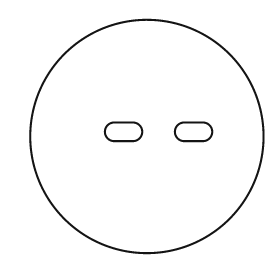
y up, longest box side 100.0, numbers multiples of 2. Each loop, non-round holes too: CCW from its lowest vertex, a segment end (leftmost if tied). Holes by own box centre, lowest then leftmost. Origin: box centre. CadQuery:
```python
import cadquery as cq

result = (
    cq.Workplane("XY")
    .moveTo(0.0, 0.0)
    .circle(50.0)
    .moveTo(-14.0, -2.0)
    .lineTo(-6.0, -2.0)
    .threePointArc((-2.0, 2.0), (-6.0, 6.0))
    .lineTo(-14.0, 6.0)
    .threePointArc((-18.0, 2.0), (-14.0, -2.0))
    .close()
    .moveTo(16.0, -2.0)
    .lineTo(24.0, -2.0)
    .threePointArc((28.0, 2.0), (24.0, 6.0))
    .lineTo(16.0, 6.0)
    .threePointArc((12.0, 2.0), (16.0, -2.0))
    .close()
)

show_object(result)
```